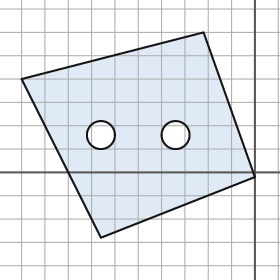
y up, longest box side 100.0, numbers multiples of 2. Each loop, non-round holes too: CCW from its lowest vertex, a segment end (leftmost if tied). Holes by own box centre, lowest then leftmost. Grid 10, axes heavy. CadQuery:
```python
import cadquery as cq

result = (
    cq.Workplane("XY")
    .moveTo(-66.0, -28.0)
    .lineTo(0.0, -2.0)
    .lineTo(-22.0, 60.0)
    .lineTo(-100.0, 40.0)
    .close()
    .moveTo(-66.0, 16.0)
    .circle(6.0)
    .moveTo(-34.0, 16.0)
    .circle(6.0)
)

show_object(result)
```